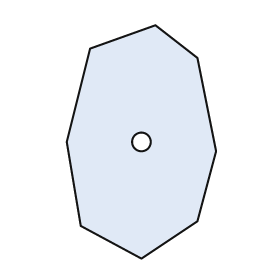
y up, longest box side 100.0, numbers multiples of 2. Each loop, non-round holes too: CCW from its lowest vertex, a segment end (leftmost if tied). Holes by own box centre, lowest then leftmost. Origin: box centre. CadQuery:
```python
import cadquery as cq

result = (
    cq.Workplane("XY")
    .moveTo(0.0, -50.0)
    .lineTo(24.0, -34.0)
    .lineTo(32.0, -4.0)
    .lineTo(24.0, 36.0)
    .lineTo(6.0, 50.0)
    .lineTo(-22.0, 40.0)
    .lineTo(-32.0, 0.0)
    .lineTo(-26.0, -36.0)
    .close()
    .moveTo(0.0, 0.0)
    .circle(4.0)
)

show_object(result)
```